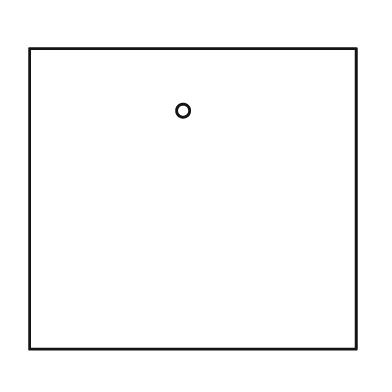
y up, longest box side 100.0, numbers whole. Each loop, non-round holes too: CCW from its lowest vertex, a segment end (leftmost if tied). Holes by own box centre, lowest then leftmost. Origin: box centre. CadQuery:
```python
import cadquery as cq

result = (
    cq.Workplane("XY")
    .moveTo(-50.0, -46.0)
    .lineTo(50.0, -46.0)
    .lineTo(50.0, 46.0)
    .lineTo(-50.0, 46.0)
    .close()
    .moveTo(-3.0, 27.0)
    .circle(2.0)
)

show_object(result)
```